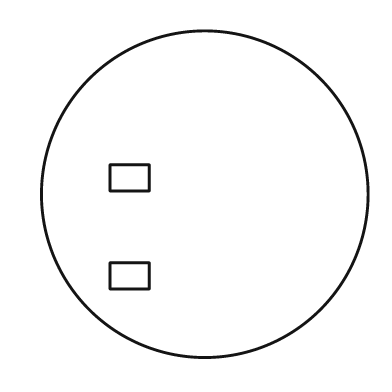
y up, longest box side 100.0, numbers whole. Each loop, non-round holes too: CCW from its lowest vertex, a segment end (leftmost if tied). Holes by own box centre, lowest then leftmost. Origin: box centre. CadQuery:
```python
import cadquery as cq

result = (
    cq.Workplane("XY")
    .moveTo(0.0, 0.0)
    .circle(50.0)
    .moveTo(-29.0, -29.0)
    .lineTo(-17.0, -29.0)
    .lineTo(-17.0, -21.0)
    .lineTo(-29.0, -21.0)
    .close()
    .moveTo(-29.0, 1.0)
    .lineTo(-17.0, 1.0)
    .lineTo(-17.0, 9.0)
    .lineTo(-29.0, 9.0)
    .close()
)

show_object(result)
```